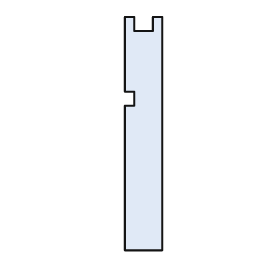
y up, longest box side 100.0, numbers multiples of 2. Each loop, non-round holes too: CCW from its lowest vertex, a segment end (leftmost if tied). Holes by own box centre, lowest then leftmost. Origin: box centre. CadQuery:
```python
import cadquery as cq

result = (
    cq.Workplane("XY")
    .moveTo(-8.0, -50.0)
    .lineTo(8.0, -50.0)
    .lineTo(8.0, 50.0)
    .lineTo(4.0, 50.0)
    .lineTo(4.0, 44.0)
    .lineTo(-4.0, 44.0)
    .lineTo(-4.0, 50.0)
    .lineTo(-8.0, 50.0)
    .lineTo(-8.0, 18.0)
    .lineTo(-4.0, 18.0)
    .lineTo(-4.0, 12.0)
    .lineTo(-8.0, 12.0)
    .close()
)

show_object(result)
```